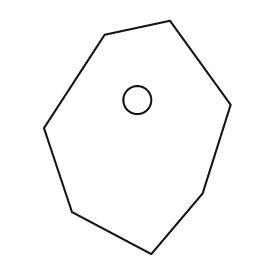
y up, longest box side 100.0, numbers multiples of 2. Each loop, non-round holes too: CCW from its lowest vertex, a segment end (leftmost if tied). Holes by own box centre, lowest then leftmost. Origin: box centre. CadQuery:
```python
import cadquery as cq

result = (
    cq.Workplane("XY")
    .moveTo(6.0, -50.0)
    .lineTo(28.0, -24.0)
    .lineTo(40.0, 14.0)
    .lineTo(14.0, 50.0)
    .lineTo(-14.0, 44.0)
    .lineTo(-40.0, 4.0)
    .lineTo(-28.0, -32.0)
    .close()
    .moveTo(0.0, 16.0)
    .circle(6.0)
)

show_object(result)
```